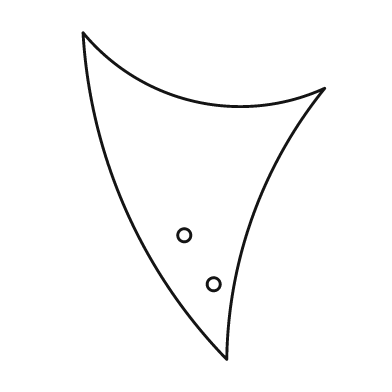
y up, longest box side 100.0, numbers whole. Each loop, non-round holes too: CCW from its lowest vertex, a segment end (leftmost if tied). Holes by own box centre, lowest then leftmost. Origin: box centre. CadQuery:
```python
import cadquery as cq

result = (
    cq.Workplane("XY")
    .moveTo(7.0, -50.0)
    .threePointArc((15.0, -6.0), (37.0, 33.0))
    .threePointArc((-3.0, 29.0), (-37.0, 50.0))
    .threePointArc((-24.0, -4.0), (7.0, -50.0))
    .close()
    .moveTo(3.0, -27.0)
    .circle(2.0)
    .moveTo(-6.0, -12.0)
    .circle(2.0)
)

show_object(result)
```